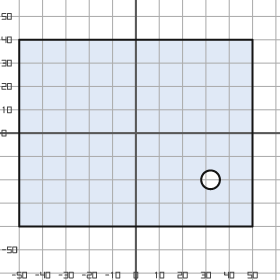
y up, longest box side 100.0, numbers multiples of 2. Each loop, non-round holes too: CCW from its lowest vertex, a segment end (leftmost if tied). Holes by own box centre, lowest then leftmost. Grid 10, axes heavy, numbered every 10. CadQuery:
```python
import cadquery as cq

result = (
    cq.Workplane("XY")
    .moveTo(-50.0, -40.0)
    .lineTo(50.0, -40.0)
    .lineTo(50.0, 40.0)
    .lineTo(-50.0, 40.0)
    .close()
    .moveTo(32.0, -20.0)
    .circle(4.0)
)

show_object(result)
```